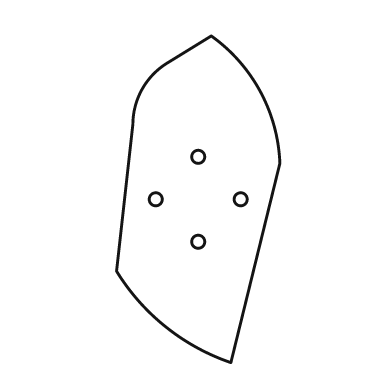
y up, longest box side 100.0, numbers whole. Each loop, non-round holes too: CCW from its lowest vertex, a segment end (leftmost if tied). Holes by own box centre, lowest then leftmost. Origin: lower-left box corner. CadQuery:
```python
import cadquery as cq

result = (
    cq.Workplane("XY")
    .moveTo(35.0, 0.0)
    .lineTo(50.0, 61.0)
    .threePointArc((44.0, 83.0), (29.0, 100.0))
    .lineTo(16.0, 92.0)
    .threePointArc((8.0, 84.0), (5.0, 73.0))
    .lineTo(0.0, 28.0)
    .threePointArc((15.0, 11.0), (35.0, 0.0))
    .close()
    .moveTo(25.0, 37.0)
    .circle(2.0)
    .moveTo(12.0, 50.0)
    .circle(2.0)
    .moveTo(38.0, 50.0)
    .circle(2.0)
    .moveTo(25.0, 63.0)
    .circle(2.0)
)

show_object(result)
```